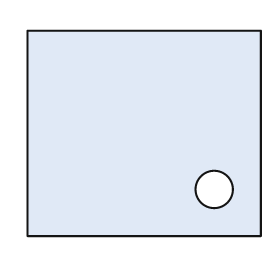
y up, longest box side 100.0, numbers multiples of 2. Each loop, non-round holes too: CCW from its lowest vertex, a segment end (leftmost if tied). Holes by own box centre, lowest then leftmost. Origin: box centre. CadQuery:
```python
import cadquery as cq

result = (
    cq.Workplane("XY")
    .moveTo(-50.0, -44.0)
    .lineTo(50.0, -44.0)
    .lineTo(50.0, 44.0)
    .lineTo(-50.0, 44.0)
    .close()
    .moveTo(30.0, -24.0)
    .circle(8.0)
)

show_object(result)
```